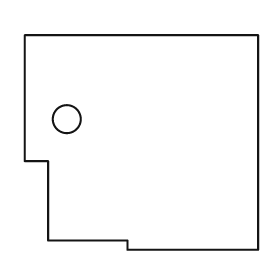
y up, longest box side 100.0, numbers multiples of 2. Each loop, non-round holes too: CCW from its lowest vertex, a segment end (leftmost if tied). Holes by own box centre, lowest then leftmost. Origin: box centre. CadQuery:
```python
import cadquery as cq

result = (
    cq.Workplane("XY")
    .moveTo(-6.0, -46.0)
    .lineTo(50.0, -46.0)
    .lineTo(50.0, 46.0)
    .lineTo(-50.0, 46.0)
    .lineTo(-50.0, -8.0)
    .lineTo(-40.0, -8.0)
    .lineTo(-40.0, -42.0)
    .lineTo(-6.0, -42.0)
    .close()
    .moveTo(-32.0, 10.0)
    .circle(6.0)
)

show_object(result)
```